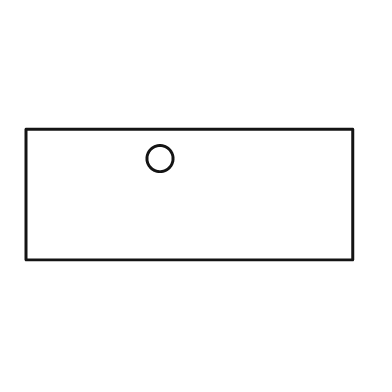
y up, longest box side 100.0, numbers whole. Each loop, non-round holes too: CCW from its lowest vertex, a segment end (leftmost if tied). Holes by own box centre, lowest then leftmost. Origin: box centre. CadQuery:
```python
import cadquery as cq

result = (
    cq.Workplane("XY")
    .moveTo(-50.0, -20.0)
    .lineTo(50.0, -20.0)
    .lineTo(50.0, 20.0)
    .lineTo(-50.0, 20.0)
    .close()
    .moveTo(-9.0, 11.0)
    .circle(4.0)
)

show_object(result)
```